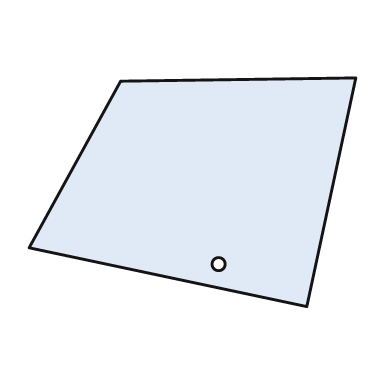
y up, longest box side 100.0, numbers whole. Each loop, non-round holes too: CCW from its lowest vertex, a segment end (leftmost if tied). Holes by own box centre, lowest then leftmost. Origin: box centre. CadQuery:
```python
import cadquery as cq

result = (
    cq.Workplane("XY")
    .moveTo(35.0, -35.0)
    .lineTo(50.0, 35.0)
    .lineTo(-22.0, 34.0)
    .lineTo(-50.0, -17.0)
    .close()
    .moveTo(8.0, -22.0)
    .circle(2.0)
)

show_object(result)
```